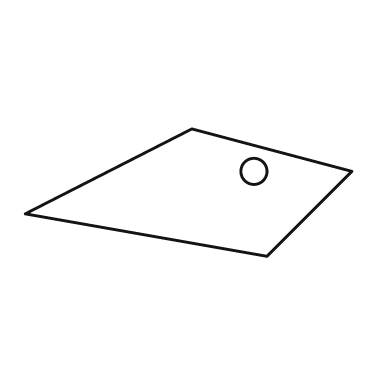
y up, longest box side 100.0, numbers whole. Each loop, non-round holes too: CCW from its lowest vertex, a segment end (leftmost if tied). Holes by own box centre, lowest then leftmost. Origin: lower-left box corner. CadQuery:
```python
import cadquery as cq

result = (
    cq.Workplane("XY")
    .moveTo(74.0, 0.0)
    .lineTo(100.0, 26.0)
    .lineTo(51.0, 39.0)
    .lineTo(0.0, 13.0)
    .close()
    .moveTo(70.0, 26.0)
    .circle(4.0)
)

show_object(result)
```